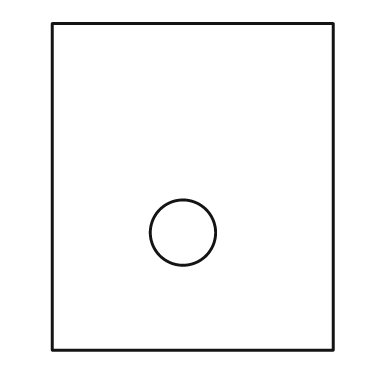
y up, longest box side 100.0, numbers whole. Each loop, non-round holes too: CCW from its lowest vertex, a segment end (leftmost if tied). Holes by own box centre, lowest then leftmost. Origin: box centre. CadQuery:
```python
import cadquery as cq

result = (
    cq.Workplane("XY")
    .moveTo(-43.0, -50.0)
    .lineTo(43.0, -50.0)
    .lineTo(43.0, 50.0)
    .lineTo(-43.0, 50.0)
    .close()
    .moveTo(-3.0, -14.0)
    .circle(10.0)
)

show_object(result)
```